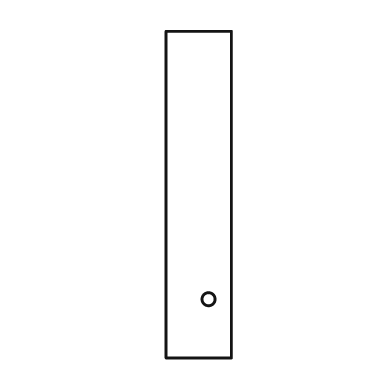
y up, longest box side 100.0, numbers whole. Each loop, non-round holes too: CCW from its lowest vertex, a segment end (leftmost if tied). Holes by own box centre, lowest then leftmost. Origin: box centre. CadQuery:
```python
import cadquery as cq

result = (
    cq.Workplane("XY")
    .moveTo(-10.0, -50.0)
    .lineTo(10.0, -50.0)
    .lineTo(10.0, 50.0)
    .lineTo(-10.0, 50.0)
    .close()
    .moveTo(3.0, -32.0)
    .circle(2.0)
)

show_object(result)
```